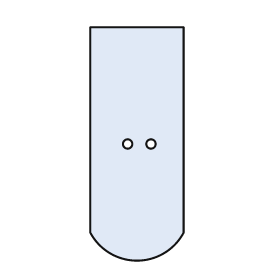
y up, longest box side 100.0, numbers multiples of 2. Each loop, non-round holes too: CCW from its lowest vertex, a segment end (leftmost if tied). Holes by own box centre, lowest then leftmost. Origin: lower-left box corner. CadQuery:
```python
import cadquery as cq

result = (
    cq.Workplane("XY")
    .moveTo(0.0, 12.0)
    .threePointArc((20.0, 0.0), (40.0, 12.0))
    .lineTo(40.0, 100.0)
    .lineTo(0.0, 100.0)
    .close()
    .moveTo(16.0, 50.0)
    .circle(2.0)
    .moveTo(26.0, 50.0)
    .circle(2.0)
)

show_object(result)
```